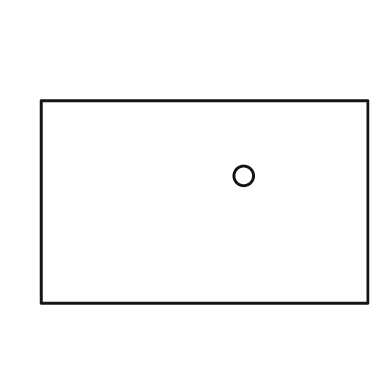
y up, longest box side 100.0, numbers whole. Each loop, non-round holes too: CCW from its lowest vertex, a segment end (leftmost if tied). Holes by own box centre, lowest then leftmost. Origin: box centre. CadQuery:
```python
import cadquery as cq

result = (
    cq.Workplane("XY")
    .moveTo(-50.0, -31.0)
    .lineTo(50.0, -31.0)
    .lineTo(50.0, 31.0)
    .lineTo(-50.0, 31.0)
    .close()
    .moveTo(12.0, 8.0)
    .circle(3.0)
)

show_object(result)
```